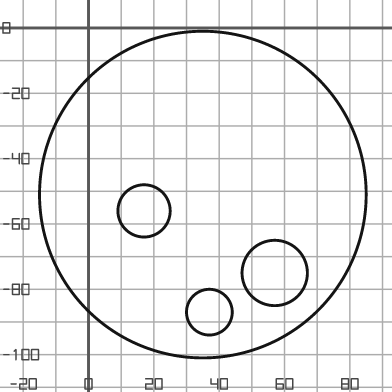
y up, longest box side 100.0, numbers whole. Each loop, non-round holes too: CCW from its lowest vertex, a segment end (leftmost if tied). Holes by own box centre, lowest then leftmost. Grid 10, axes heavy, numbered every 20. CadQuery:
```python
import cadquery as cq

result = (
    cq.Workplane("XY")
    .moveTo(35.0, -51.0)
    .circle(50.0)
    .moveTo(37.0, -87.0)
    .circle(7.0)
    .moveTo(57.0, -75.0)
    .circle(10.0)
    .moveTo(17.0, -56.0)
    .circle(8.0)
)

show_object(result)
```